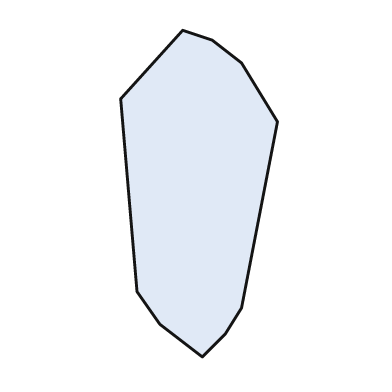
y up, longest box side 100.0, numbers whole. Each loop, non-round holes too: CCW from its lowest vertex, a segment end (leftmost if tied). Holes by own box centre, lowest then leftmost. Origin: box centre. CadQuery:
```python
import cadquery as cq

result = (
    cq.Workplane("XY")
    .moveTo(1.0, -50.0)
    .lineTo(8.0, -43.0)
    .lineTo(13.0, -35.0)
    .lineTo(24.0, 22.0)
    .lineTo(13.0, 40.0)
    .lineTo(4.0, 47.0)
    .lineTo(-5.0, 50.0)
    .lineTo(-24.0, 29.0)
    .lineTo(-19.0, -30.0)
    .lineTo(-12.0, -40.0)
    .close()
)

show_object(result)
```